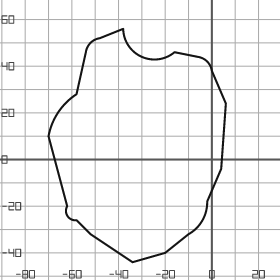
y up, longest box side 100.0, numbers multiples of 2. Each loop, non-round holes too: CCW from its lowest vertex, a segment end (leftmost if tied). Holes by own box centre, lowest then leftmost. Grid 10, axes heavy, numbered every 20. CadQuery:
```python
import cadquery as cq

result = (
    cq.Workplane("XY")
    .moveTo(-34.0, -44.0)
    .lineTo(-20.0, -40.0)
    .lineTo(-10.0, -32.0)
    .threePointArc((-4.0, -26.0), (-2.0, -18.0))
    .lineTo(4.0, -4.0)
    .lineTo(6.0, 24.0)
    .lineTo(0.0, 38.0)
    .threePointArc((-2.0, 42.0), (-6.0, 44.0))
    .lineTo(-16.0, 46.0)
    .threePointArc((-30.0, 44.0), (-38.0, 56.0))
    .lineTo(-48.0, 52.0)
    .threePointArc((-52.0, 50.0), (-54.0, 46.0))
    .lineTo(-58.0, 28.0)
    .threePointArc((-66.0, 20.0), (-70.0, 10.0))
    .lineTo(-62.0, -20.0)
    .threePointArc((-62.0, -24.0), (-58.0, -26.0))
    .lineTo(-52.0, -32.0)
    .close()
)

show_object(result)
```